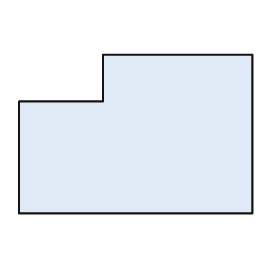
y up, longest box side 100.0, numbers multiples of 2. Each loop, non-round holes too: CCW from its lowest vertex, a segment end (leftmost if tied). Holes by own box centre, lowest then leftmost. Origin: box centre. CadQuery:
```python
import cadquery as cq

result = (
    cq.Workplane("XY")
    .moveTo(-50.0, -34.0)
    .lineTo(50.0, -34.0)
    .lineTo(50.0, 34.0)
    .lineTo(-14.0, 34.0)
    .lineTo(-14.0, 14.0)
    .lineTo(-50.0, 14.0)
    .close()
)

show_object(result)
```